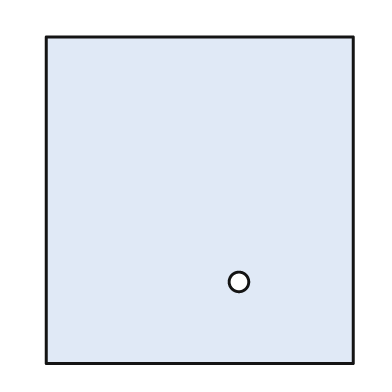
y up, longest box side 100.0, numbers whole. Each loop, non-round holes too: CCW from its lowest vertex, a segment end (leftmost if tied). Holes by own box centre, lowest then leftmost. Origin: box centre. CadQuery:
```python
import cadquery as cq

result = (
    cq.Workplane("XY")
    .moveTo(-47.0, -50.0)
    .lineTo(47.0, -50.0)
    .lineTo(47.0, 50.0)
    .lineTo(-47.0, 50.0)
    .close()
    .moveTo(12.0, -25.0)
    .circle(3.0)
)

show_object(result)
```